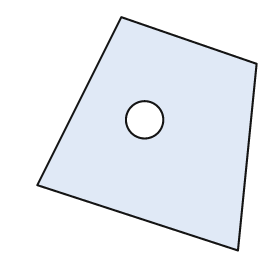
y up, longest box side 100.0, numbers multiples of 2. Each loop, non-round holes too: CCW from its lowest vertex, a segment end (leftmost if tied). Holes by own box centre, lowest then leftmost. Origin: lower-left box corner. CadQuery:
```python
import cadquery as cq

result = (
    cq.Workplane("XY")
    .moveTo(86.0, 0.0)
    .lineTo(94.0, 80.0)
    .lineTo(36.0, 100.0)
    .lineTo(0.0, 28.0)
    .close()
    .moveTo(46.0, 56.0)
    .circle(8.0)
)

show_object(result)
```